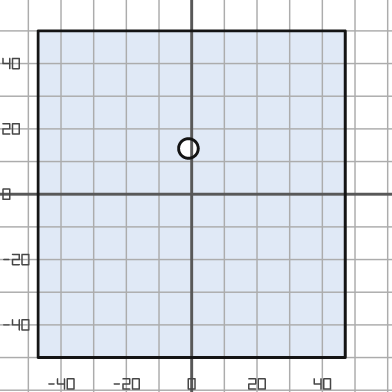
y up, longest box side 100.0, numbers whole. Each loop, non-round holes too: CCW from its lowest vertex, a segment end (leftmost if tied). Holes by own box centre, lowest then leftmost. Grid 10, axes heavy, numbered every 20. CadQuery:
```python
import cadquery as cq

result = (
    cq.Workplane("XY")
    .moveTo(-47.0, -50.0)
    .lineTo(47.0, -50.0)
    .lineTo(47.0, 50.0)
    .lineTo(-47.0, 50.0)
    .close()
    .moveTo(-1.0, 14.0)
    .circle(3.0)
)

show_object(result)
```